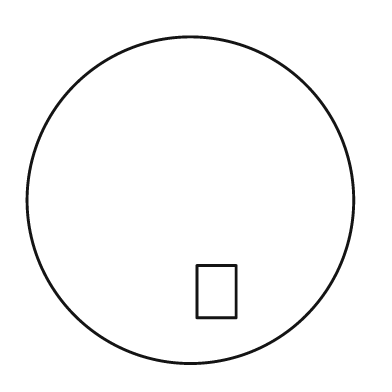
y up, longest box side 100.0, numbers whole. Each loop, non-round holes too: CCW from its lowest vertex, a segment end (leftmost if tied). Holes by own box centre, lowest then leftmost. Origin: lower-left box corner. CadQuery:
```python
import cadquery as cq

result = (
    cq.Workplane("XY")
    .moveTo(50.0, 50.0)
    .circle(50.0)
    .moveTo(52.0, 14.0)
    .lineTo(64.0, 14.0)
    .lineTo(64.0, 30.0)
    .lineTo(52.0, 30.0)
    .close()
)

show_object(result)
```